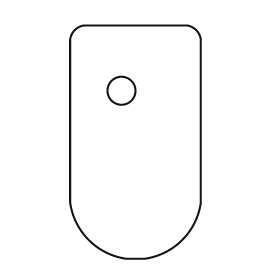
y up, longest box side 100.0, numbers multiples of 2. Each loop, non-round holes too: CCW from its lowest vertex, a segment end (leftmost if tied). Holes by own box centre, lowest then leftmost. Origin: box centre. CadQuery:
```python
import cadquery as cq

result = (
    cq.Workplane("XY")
    .moveTo(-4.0, -50.0)
    .lineTo(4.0, -50.0)
    .threePointArc((20.0, -42.0), (28.0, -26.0))
    .lineTo(28.0, 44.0)
    .threePointArc((26.0, 48.0), (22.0, 50.0))
    .lineTo(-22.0, 50.0)
    .threePointArc((-26.0, 48.0), (-28.0, 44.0))
    .lineTo(-28.0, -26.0)
    .threePointArc((-20.0, -42.0), (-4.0, -50.0))
    .close()
    .moveTo(-6.0, 22.0)
    .circle(6.0)
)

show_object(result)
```